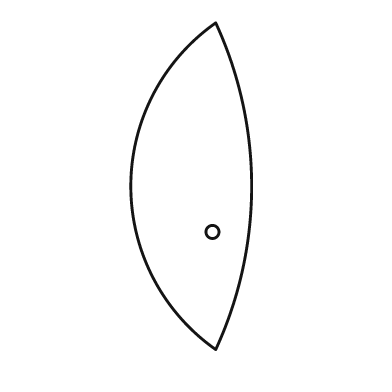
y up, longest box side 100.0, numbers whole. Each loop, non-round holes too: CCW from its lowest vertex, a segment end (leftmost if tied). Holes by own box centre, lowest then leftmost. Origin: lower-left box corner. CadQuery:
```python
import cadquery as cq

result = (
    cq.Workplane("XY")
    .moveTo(26.0, 0.0)
    .threePointArc((37.0, 50.0), (26.0, 100.0))
    .threePointArc((0.0, 50.0), (26.0, 0.0))
    .close()
    .moveTo(25.0, 36.0)
    .circle(2.0)
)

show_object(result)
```